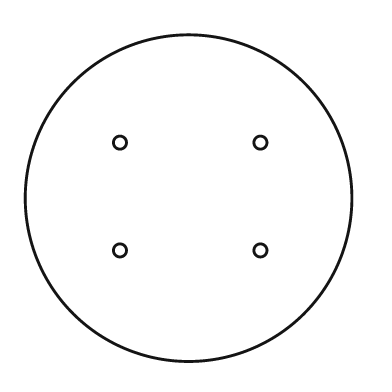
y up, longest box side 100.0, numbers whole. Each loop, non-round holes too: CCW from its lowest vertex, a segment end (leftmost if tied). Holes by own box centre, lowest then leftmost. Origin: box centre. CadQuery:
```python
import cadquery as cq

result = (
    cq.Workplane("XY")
    .moveTo(0.0, 0.0)
    .circle(50.0)
    .moveTo(-21.0, -16.0)
    .circle(2.0)
    .moveTo(22.0, -16.0)
    .circle(2.0)
    .moveTo(-21.0, 17.0)
    .circle(2.0)
    .moveTo(22.0, 17.0)
    .circle(2.0)
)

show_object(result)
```